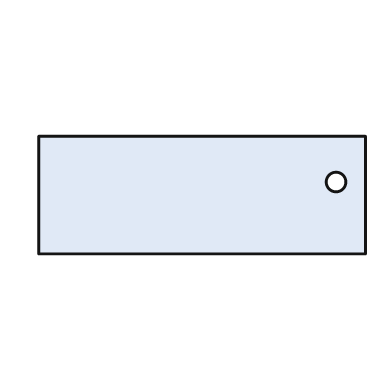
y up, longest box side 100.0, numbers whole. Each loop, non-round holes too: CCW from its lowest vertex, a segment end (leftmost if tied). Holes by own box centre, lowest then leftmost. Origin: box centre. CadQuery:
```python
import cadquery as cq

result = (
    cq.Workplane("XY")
    .moveTo(-50.0, -18.0)
    .lineTo(50.0, -18.0)
    .lineTo(50.0, 18.0)
    .lineTo(-50.0, 18.0)
    .close()
    .moveTo(41.0, 4.0)
    .circle(3.0)
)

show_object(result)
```